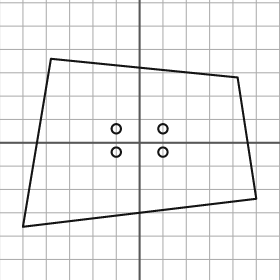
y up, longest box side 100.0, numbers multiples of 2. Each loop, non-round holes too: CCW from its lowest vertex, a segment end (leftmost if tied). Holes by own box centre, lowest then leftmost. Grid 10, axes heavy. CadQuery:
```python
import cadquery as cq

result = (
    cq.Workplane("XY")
    .moveTo(-50.0, -36.0)
    .lineTo(50.0, -24.0)
    .lineTo(42.0, 28.0)
    .lineTo(-38.0, 36.0)
    .close()
    .moveTo(-10.0, -4.0)
    .circle(2.0)
    .moveTo(10.0, -4.0)
    .circle(2.0)
    .moveTo(-10.0, 6.0)
    .circle(2.0)
    .moveTo(10.0, 6.0)
    .circle(2.0)
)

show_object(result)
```